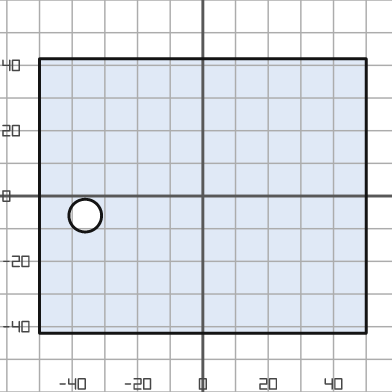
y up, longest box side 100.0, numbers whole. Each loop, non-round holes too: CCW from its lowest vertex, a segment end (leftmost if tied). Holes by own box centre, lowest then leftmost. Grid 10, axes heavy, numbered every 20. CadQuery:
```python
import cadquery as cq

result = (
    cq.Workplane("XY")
    .moveTo(-50.0, -42.0)
    .lineTo(50.0, -42.0)
    .lineTo(50.0, 42.0)
    .lineTo(-50.0, 42.0)
    .close()
    .moveTo(-36.0, -6.0)
    .circle(5.0)
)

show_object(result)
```